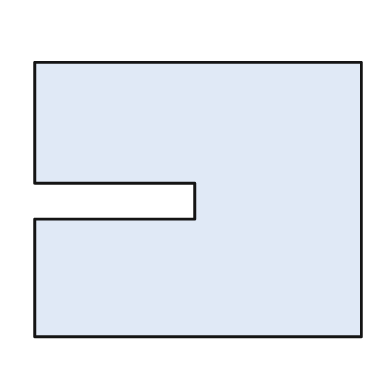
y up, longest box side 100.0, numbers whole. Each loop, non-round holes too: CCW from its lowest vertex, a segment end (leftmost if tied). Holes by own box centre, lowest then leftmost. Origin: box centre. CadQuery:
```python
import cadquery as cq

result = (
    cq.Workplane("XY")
    .moveTo(-50.0, -42.0)
    .lineTo(50.0, -42.0)
    .lineTo(50.0, 42.0)
    .lineTo(-50.0, 42.0)
    .lineTo(-50.0, 5.0)
    .lineTo(-1.0, 5.0)
    .lineTo(-1.0, -6.0)
    .lineTo(-50.0, -6.0)
    .close()
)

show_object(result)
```